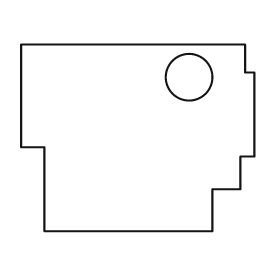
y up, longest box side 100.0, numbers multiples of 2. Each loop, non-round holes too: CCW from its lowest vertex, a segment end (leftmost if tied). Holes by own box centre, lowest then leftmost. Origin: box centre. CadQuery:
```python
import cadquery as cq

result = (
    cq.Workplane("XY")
    .moveTo(-40.0, -40.0)
    .lineTo(32.0, -40.0)
    .lineTo(32.0, -22.0)
    .lineTo(44.0, -22.0)
    .lineTo(44.0, -8.0)
    .lineTo(50.0, -8.0)
    .lineTo(50.0, 28.0)
    .lineTo(46.0, 28.0)
    .lineTo(46.0, 40.0)
    .lineTo(-50.0, 40.0)
    .lineTo(-50.0, -4.0)
    .lineTo(-40.0, -4.0)
    .close()
    .moveTo(22.0, 26.0)
    .circle(10.0)
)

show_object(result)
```